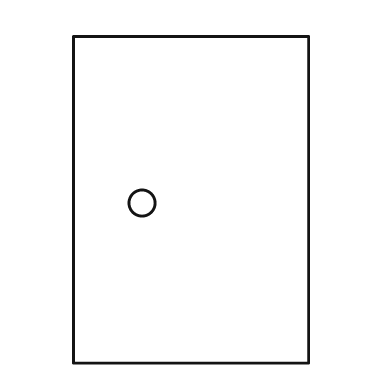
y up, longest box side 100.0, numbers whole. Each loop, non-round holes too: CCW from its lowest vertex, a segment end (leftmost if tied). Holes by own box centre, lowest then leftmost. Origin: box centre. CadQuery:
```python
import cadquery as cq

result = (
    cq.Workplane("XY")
    .moveTo(-36.0, -50.0)
    .lineTo(36.0, -50.0)
    .lineTo(36.0, 50.0)
    .lineTo(-36.0, 50.0)
    .close()
    .moveTo(-15.0, -1.0)
    .circle(4.0)
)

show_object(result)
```